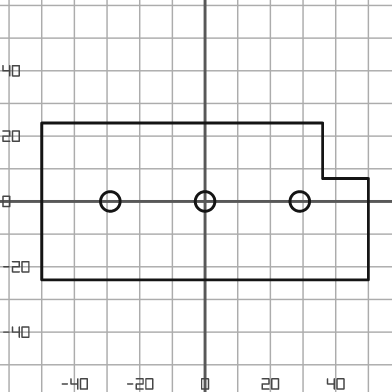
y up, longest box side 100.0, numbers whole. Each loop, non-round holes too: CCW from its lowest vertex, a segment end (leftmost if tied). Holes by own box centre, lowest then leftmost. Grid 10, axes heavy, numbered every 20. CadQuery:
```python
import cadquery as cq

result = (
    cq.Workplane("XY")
    .moveTo(-50.0, -24.0)
    .lineTo(50.0, -24.0)
    .lineTo(50.0, 7.0)
    .lineTo(36.0, 7.0)
    .lineTo(36.0, 24.0)
    .lineTo(-50.0, 24.0)
    .close()
    .moveTo(-29.0, 0.0)
    .circle(3.0)
    .moveTo(0.0, 0.0)
    .circle(3.0)
    .moveTo(29.0, 0.0)
    .circle(3.0)
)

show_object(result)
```